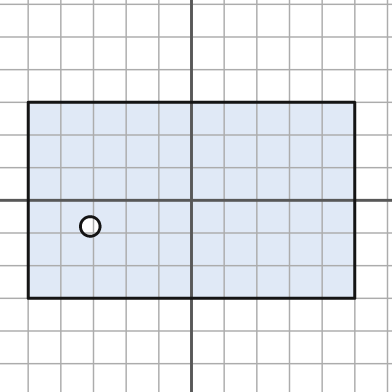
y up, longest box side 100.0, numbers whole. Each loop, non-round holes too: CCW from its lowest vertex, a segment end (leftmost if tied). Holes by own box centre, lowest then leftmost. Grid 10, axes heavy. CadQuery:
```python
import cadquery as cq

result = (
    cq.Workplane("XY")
    .moveTo(-50.0, -30.0)
    .lineTo(50.0, -30.0)
    .lineTo(50.0, 30.0)
    .lineTo(-50.0, 30.0)
    .close()
    .moveTo(-31.0, -8.0)
    .circle(3.0)
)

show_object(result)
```